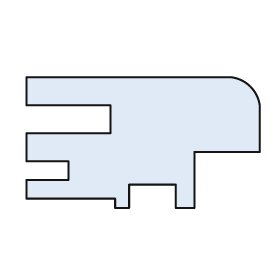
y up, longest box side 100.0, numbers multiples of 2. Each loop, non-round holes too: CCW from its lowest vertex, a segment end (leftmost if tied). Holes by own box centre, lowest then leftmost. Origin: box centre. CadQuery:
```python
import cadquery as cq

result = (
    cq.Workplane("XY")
    .moveTo(-12.0, -28.0)
    .lineTo(-6.0, -28.0)
    .lineTo(-6.0, -18.0)
    .lineTo(14.0, -18.0)
    .lineTo(14.0, -28.0)
    .lineTo(22.0, -28.0)
    .lineTo(22.0, -4.0)
    .lineTo(50.0, -4.0)
    .lineTo(50.0, 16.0)
    .threePointArc((46.0, 24.0), (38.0, 28.0))
    .lineTo(-50.0, 28.0)
    .lineTo(-50.0, 16.0)
    .lineTo(-14.0, 16.0)
    .lineTo(-14.0, 4.0)
    .lineTo(-50.0, 4.0)
    .lineTo(-50.0, -8.0)
    .lineTo(-32.0, -8.0)
    .lineTo(-32.0, -16.0)
    .lineTo(-50.0, -16.0)
    .lineTo(-50.0, -24.0)
    .lineTo(-12.0, -24.0)
    .close()
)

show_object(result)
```